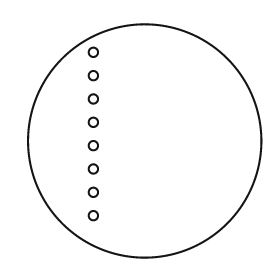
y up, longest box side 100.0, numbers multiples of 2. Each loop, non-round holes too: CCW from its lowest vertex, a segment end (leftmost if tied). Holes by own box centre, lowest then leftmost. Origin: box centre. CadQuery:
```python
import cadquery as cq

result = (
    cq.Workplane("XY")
    .moveTo(0.0, 0.0)
    .circle(50.0)
    .moveTo(-22.0, -32.0)
    .circle(2.0)
    .moveTo(-22.0, -22.0)
    .circle(2.0)
    .moveTo(-22.0, -12.0)
    .circle(2.0)
    .moveTo(-22.0, -2.0)
    .circle(2.0)
    .moveTo(-22.0, 8.0)
    .circle(2.0)
    .moveTo(-22.0, 18.0)
    .circle(2.0)
    .moveTo(-22.0, 28.0)
    .circle(2.0)
    .moveTo(-22.0, 38.0)
    .circle(2.0)
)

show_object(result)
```